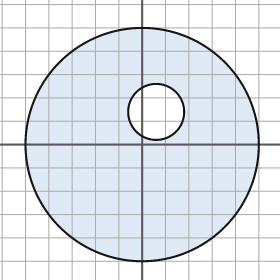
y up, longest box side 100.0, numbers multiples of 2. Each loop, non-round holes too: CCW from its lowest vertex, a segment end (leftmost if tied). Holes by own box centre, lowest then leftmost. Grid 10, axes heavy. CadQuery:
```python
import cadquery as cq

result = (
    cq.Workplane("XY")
    .moveTo(0.0, 0.0)
    .circle(50.0)
    .moveTo(6.0, 14.0)
    .circle(12.0)
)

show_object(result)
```